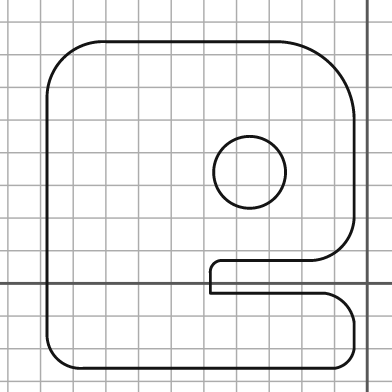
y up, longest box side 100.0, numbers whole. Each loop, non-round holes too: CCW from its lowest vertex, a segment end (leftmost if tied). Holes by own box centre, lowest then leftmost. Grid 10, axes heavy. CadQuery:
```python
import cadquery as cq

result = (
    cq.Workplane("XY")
    .moveTo(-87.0, -26.0)
    .lineTo(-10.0, -26.0)
    .threePointArc((-6.0, -24.0), (-4.0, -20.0))
    .lineTo(-4.0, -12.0)
    .threePointArc((-7.0, -6.0), (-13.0, -3.0))
    .lineTo(-48.0, -3.0)
    .lineTo(-48.0, 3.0)
    .threePointArc((-47.0, 6.0), (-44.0, 7.0))
    .lineTo(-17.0, 7.0)
    .threePointArc((-8.0, 11.0), (-4.0, 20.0))
    .lineTo(-4.0, 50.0)
    .threePointArc((-11.0, 67.0), (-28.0, 74.0))
    .lineTo(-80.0, 74.0)
    .threePointArc((-93.0, 69.0), (-98.0, 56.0))
    .lineTo(-98.0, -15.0)
    .threePointArc((-95.0, -23.0), (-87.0, -26.0))
    .close()
    .moveTo(-36.0, 34.0)
    .circle(11.0)
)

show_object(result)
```